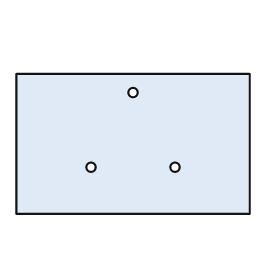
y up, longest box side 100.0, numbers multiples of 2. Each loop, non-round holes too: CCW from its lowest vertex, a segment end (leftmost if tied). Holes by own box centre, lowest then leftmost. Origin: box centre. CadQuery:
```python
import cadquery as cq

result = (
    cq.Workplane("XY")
    .moveTo(-50.0, -30.0)
    .lineTo(50.0, -30.0)
    .lineTo(50.0, 30.0)
    .lineTo(-50.0, 30.0)
    .close()
    .moveTo(-18.0, -10.0)
    .circle(2.0)
    .moveTo(18.0, -10.0)
    .circle(2.0)
    .moveTo(0.0, 22.0)
    .circle(2.0)
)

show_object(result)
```